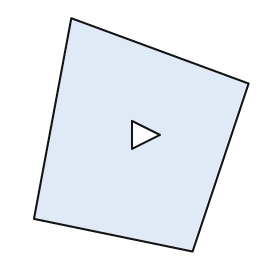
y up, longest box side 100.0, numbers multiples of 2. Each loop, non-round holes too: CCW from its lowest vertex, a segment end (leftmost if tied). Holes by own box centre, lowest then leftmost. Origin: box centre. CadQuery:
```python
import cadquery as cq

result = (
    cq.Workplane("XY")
    .moveTo(22.0, -50.0)
    .lineTo(46.0, 22.0)
    .lineTo(-30.0, 50.0)
    .lineTo(-46.0, -36.0)
    .close()
    .moveTo(-4.0, -6.0)
    .lineTo(8.0, 0.0)
    .lineTo(-4.0, 6.0)
    .close()
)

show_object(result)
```